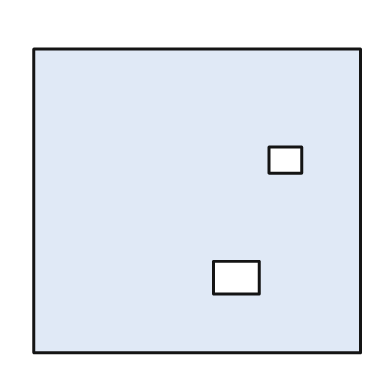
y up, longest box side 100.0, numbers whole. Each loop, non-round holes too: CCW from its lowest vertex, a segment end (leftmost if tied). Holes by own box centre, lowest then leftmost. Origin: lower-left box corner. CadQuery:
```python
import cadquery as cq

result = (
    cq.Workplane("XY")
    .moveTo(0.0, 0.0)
    .lineTo(100.0, 0.0)
    .lineTo(100.0, 93.0)
    .lineTo(0.0, 93.0)
    .close()
    .moveTo(55.0, 18.0)
    .lineTo(69.0, 18.0)
    .lineTo(69.0, 28.0)
    .lineTo(55.0, 28.0)
    .close()
    .moveTo(72.0, 55.0)
    .lineTo(82.0, 55.0)
    .lineTo(82.0, 63.0)
    .lineTo(72.0, 63.0)
    .close()
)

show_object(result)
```